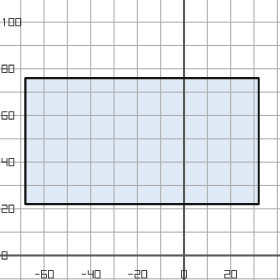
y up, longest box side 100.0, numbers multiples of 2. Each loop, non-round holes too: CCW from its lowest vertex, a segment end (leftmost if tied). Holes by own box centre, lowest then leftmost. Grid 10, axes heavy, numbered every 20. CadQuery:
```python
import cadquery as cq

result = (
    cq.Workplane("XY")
    .moveTo(-68.0, 22.0)
    .lineTo(32.0, 22.0)
    .lineTo(32.0, 76.0)
    .lineTo(-68.0, 76.0)
    .close()
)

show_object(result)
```